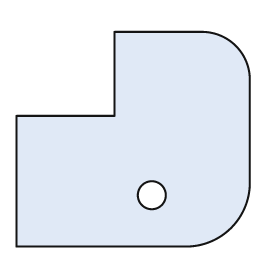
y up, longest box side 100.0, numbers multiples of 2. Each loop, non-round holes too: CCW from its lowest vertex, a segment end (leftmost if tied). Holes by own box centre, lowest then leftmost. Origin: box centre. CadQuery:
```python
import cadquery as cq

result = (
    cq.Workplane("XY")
    .moveTo(-50.0, -46.0)
    .lineTo(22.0, -46.0)
    .threePointArc((42.0, -38.0), (50.0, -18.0))
    .lineTo(50.0, 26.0)
    .threePointArc((44.0, 40.0), (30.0, 46.0))
    .lineTo(-8.0, 46.0)
    .lineTo(-8.0, 10.0)
    .lineTo(-50.0, 10.0)
    .close()
    .moveTo(8.0, -24.0)
    .circle(6.0)
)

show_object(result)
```